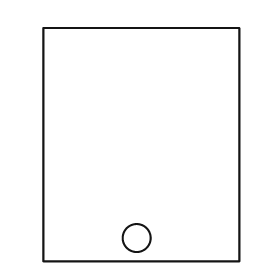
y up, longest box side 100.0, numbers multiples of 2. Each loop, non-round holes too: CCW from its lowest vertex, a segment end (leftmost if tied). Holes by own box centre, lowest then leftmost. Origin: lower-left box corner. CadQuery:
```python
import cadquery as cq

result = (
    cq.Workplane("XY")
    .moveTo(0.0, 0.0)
    .lineTo(84.0, 0.0)
    .lineTo(84.0, 100.0)
    .lineTo(0.0, 100.0)
    .close()
    .moveTo(40.0, 10.0)
    .circle(6.0)
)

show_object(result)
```